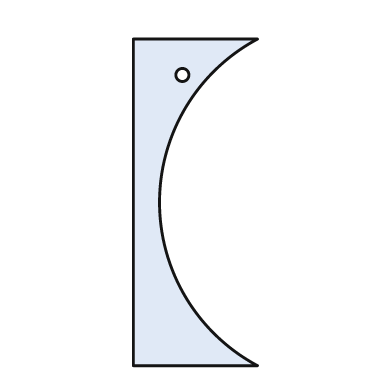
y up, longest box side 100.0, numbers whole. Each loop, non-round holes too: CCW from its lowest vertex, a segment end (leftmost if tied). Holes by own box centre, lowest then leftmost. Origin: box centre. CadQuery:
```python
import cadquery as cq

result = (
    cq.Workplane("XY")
    .moveTo(-19.0, -50.0)
    .lineTo(19.0, -50.0)
    .threePointArc((-11.0, 0.0), (19.0, 50.0))
    .lineTo(-19.0, 50.0)
    .close()
    .moveTo(-4.0, 39.0)
    .circle(2.0)
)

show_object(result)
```